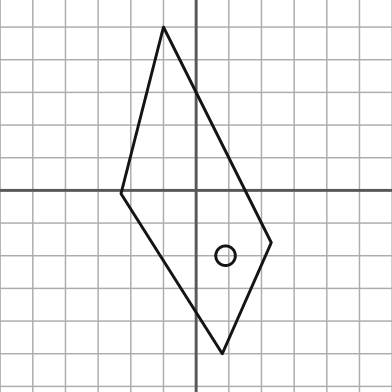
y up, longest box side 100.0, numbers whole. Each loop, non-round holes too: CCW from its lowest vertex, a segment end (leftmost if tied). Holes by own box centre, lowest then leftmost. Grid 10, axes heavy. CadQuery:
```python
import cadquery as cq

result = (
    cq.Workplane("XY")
    .moveTo(8.0, -50.0)
    .lineTo(23.0, -16.0)
    .lineTo(-10.0, 50.0)
    .lineTo(-23.0, -1.0)
    .close()
    .moveTo(9.0, -20.0)
    .circle(3.0)
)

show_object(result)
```